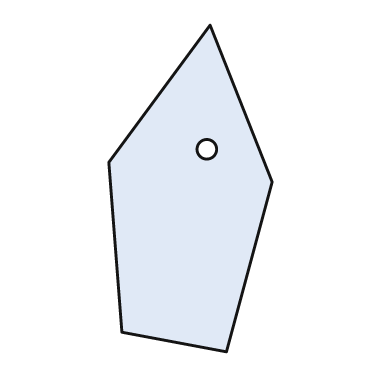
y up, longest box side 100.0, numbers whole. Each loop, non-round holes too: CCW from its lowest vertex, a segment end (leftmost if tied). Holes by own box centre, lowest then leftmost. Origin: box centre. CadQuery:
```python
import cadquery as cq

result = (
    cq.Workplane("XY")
    .moveTo(11.0, -50.0)
    .lineTo(25.0, 2.0)
    .lineTo(6.0, 50.0)
    .lineTo(-25.0, 8.0)
    .lineTo(-21.0, -44.0)
    .close()
    .moveTo(5.0, 12.0)
    .circle(3.0)
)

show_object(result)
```